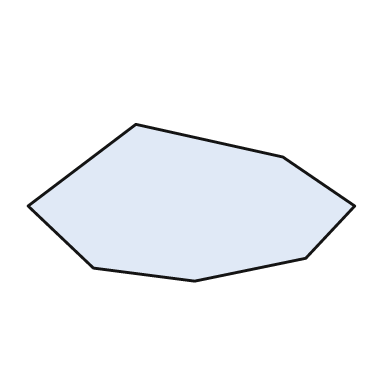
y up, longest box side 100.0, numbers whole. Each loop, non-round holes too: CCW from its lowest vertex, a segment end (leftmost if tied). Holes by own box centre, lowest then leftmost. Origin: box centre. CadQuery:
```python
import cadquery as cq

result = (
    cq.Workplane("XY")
    .moveTo(1.0, -24.0)
    .lineTo(35.0, -17.0)
    .lineTo(50.0, -1.0)
    .lineTo(28.0, 14.0)
    .lineTo(-17.0, 24.0)
    .lineTo(-50.0, -1.0)
    .lineTo(-30.0, -20.0)
    .close()
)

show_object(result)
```